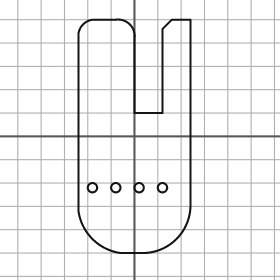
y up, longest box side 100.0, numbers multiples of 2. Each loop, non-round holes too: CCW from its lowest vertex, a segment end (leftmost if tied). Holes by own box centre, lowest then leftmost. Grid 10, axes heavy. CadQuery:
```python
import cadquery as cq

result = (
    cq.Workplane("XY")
    .moveTo(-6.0, -50.0)
    .lineTo(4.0, -50.0)
    .threePointArc((18.0, -44.0), (24.0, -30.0))
    .lineTo(24.0, 50.0)
    .lineTo(16.0, 50.0)
    .lineTo(12.0, 46.0)
    .lineTo(12.0, 10.0)
    .lineTo(0.0, 10.0)
    .lineTo(0.0, 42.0)
    .threePointArc((-2.0, 48.0), (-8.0, 50.0))
    .lineTo(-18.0, 50.0)
    .threePointArc((-22.0, 48.0), (-24.0, 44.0))
    .lineTo(-24.0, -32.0)
    .threePointArc((-18.0, -44.0), (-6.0, -50.0))
    .close()
    .moveTo(-18.0, -22.0)
    .circle(2.0)
    .moveTo(-8.0, -22.0)
    .circle(2.0)
    .moveTo(2.0, -22.0)
    .circle(2.0)
    .moveTo(12.0, -22.0)
    .circle(2.0)
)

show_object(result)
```